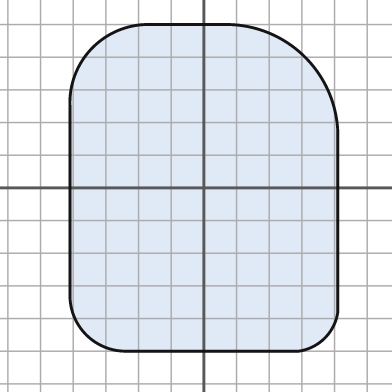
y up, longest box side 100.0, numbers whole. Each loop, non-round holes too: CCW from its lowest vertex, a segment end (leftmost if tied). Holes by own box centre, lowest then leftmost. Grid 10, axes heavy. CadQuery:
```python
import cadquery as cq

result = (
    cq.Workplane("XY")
    .moveTo(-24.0, -50.0)
    .lineTo(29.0, -50.0)
    .threePointArc((37.0, -46.0), (41.0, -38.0))
    .lineTo(41.0, 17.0)
    .threePointArc((31.0, 40.0), (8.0, 50.0))
    .lineTo(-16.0, 50.0)
    .threePointArc((-34.0, 43.0), (-41.0, 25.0))
    .lineTo(-41.0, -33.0)
    .threePointArc((-36.0, -45.0), (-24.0, -50.0))
    .close()
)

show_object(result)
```